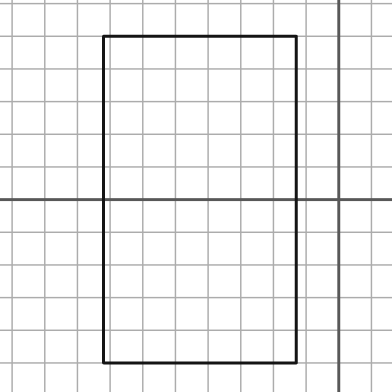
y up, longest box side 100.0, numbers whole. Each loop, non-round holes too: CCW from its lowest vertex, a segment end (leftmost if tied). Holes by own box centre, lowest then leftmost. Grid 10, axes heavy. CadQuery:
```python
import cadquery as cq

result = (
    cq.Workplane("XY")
    .moveTo(-72.0, -50.0)
    .lineTo(-13.0, -50.0)
    .lineTo(-13.0, 50.0)
    .lineTo(-72.0, 50.0)
    .close()
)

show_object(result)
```